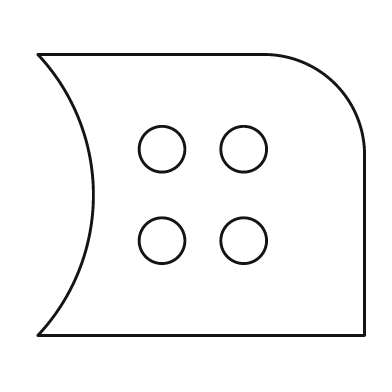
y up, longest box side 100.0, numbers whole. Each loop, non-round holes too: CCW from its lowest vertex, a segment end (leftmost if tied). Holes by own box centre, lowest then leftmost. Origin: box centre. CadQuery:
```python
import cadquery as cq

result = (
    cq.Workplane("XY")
    .moveTo(-50.0, -43.0)
    .lineTo(50.0, -43.0)
    .lineTo(50.0, 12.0)
    .threePointArc((41.0, 34.0), (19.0, 43.0))
    .lineTo(-50.0, 43.0)
    .threePointArc((-33.0, 0.0), (-50.0, -43.0))
    .close()
    .moveTo(-12.0, -14.0)
    .circle(7.0)
    .moveTo(13.0, -14.0)
    .circle(7.0)
    .moveTo(-12.0, 14.0)
    .circle(7.0)
    .moveTo(13.0, 14.0)
    .circle(7.0)
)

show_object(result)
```